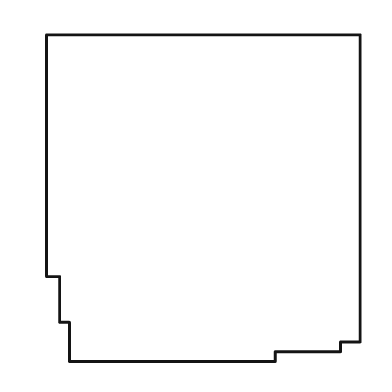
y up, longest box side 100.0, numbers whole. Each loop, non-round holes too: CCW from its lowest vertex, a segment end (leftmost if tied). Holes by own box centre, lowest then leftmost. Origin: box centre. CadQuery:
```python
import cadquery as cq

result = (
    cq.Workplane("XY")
    .moveTo(-41.0, -50.0)
    .lineTo(22.0, -50.0)
    .lineTo(22.0, -47.0)
    .lineTo(42.0, -47.0)
    .lineTo(42.0, -44.0)
    .lineTo(48.0, -44.0)
    .lineTo(48.0, 50.0)
    .lineTo(-48.0, 50.0)
    .lineTo(-48.0, -24.0)
    .lineTo(-44.0, -24.0)
    .lineTo(-44.0, -38.0)
    .lineTo(-41.0, -38.0)
    .close()
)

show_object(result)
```